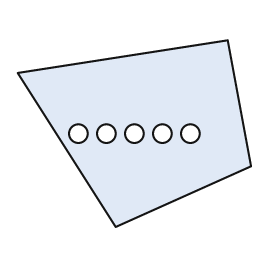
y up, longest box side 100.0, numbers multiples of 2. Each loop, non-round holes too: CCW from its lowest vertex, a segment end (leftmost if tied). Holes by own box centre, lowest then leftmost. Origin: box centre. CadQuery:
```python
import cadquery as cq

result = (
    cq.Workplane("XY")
    .moveTo(-8.0, -40.0)
    .lineTo(50.0, -14.0)
    .lineTo(40.0, 40.0)
    .lineTo(-50.0, 26.0)
    .close()
    .moveTo(-24.0, 0.0)
    .circle(4.0)
    .moveTo(-12.0, 0.0)
    .circle(4.0)
    .moveTo(0.0, 0.0)
    .circle(4.0)
    .moveTo(12.0, 0.0)
    .circle(4.0)
    .moveTo(24.0, 0.0)
    .circle(4.0)
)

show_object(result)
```